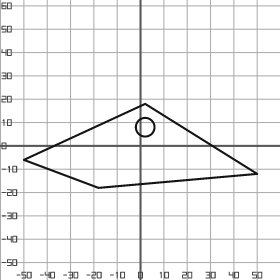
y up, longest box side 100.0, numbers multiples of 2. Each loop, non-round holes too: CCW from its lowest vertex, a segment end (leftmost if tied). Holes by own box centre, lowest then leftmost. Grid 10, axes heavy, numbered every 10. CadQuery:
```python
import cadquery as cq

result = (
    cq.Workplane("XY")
    .moveTo(-18.0, -18.0)
    .lineTo(50.0, -12.0)
    .lineTo(2.0, 18.0)
    .lineTo(-50.0, -6.0)
    .close()
    .moveTo(2.0, 8.0)
    .circle(4.0)
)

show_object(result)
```